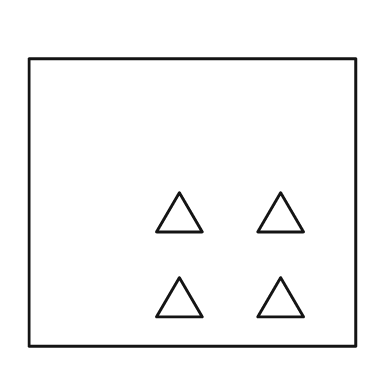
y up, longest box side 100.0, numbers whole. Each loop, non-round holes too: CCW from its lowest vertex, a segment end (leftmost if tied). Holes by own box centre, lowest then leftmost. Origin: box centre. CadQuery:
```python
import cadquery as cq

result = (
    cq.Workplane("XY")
    .moveTo(-50.0, -44.0)
    .lineTo(50.0, -44.0)
    .lineTo(50.0, 44.0)
    .lineTo(-50.0, 44.0)
    .close()
    .moveTo(-11.0, -35.0)
    .lineTo(3.0, -35.0)
    .lineTo(-4.0, -23.0)
    .close()
    .moveTo(20.0, -35.0)
    .lineTo(34.0, -35.0)
    .lineTo(27.0, -23.0)
    .close()
    .moveTo(-11.0, -9.0)
    .lineTo(3.0, -9.0)
    .lineTo(-4.0, 3.0)
    .close()
    .moveTo(20.0, -9.0)
    .lineTo(34.0, -9.0)
    .lineTo(27.0, 3.0)
    .close()
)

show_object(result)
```